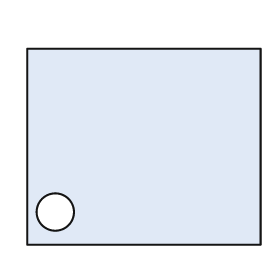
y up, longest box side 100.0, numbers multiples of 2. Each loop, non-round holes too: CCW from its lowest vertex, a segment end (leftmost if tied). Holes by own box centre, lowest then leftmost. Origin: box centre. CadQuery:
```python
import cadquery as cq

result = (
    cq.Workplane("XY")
    .moveTo(-50.0, -42.0)
    .lineTo(50.0, -42.0)
    .lineTo(50.0, 42.0)
    .lineTo(-50.0, 42.0)
    .close()
    .moveTo(-38.0, -28.0)
    .circle(8.0)
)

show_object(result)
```